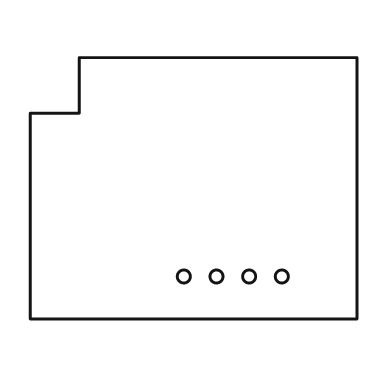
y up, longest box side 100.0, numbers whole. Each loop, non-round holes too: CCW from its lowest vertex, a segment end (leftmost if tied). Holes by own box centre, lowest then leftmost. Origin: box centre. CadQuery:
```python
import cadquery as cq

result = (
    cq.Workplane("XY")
    .moveTo(-50.0, -40.0)
    .lineTo(50.0, -40.0)
    .lineTo(50.0, 40.0)
    .lineTo(-35.0, 40.0)
    .lineTo(-35.0, 23.0)
    .lineTo(-50.0, 23.0)
    .close()
    .moveTo(-3.0, -27.0)
    .circle(2.0)
    .moveTo(7.0, -27.0)
    .circle(2.0)
    .moveTo(17.0, -27.0)
    .circle(2.0)
    .moveTo(27.0, -27.0)
    .circle(2.0)
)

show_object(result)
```